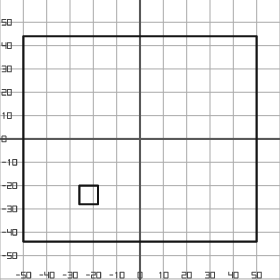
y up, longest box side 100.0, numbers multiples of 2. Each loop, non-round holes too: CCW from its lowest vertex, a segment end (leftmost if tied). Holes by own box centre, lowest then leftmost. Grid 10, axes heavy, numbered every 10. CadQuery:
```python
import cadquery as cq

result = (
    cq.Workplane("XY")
    .moveTo(-50.0, -44.0)
    .lineTo(50.0, -44.0)
    .lineTo(50.0, 44.0)
    .lineTo(-50.0, 44.0)
    .close()
    .moveTo(-26.0, -28.0)
    .lineTo(-18.0, -28.0)
    .lineTo(-18.0, -20.0)
    .lineTo(-26.0, -20.0)
    .close()
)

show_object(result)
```